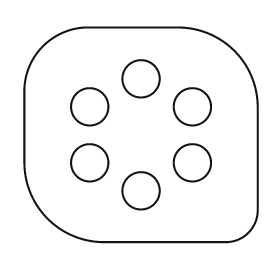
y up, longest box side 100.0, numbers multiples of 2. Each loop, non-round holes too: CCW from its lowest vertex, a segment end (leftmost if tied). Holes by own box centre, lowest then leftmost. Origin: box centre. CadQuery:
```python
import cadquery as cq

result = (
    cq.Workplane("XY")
    .moveTo(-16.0, -46.0)
    .lineTo(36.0, -46.0)
    .threePointArc((46.0, -42.0), (50.0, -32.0))
    .lineTo(50.0, 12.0)
    .threePointArc((40.0, 36.0), (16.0, 46.0))
    .lineTo(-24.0, 46.0)
    .threePointArc((-42.0, 38.0), (-50.0, 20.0))
    .lineTo(-50.0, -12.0)
    .threePointArc((-40.0, -36.0), (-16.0, -46.0))
    .close()
    .moveTo(0.0, -24.0)
    .circle(8.0)
    .moveTo(-22.0, -12.0)
    .circle(8.0)
    .moveTo(22.0, -12.0)
    .circle(8.0)
    .moveTo(-22.0, 12.0)
    .circle(8.0)
    .moveTo(22.0, 12.0)
    .circle(8.0)
    .moveTo(0.0, 24.0)
    .circle(8.0)
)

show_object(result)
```